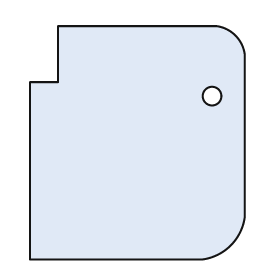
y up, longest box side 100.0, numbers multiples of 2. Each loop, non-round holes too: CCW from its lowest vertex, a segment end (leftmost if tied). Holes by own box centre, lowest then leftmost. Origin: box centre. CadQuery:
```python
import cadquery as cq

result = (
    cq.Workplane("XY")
    .moveTo(-46.0, -50.0)
    .lineTo(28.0, -50.0)
    .threePointArc((40.0, -44.0), (46.0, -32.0))
    .lineTo(46.0, 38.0)
    .threePointArc((42.0, 46.0), (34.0, 50.0))
    .lineTo(-34.0, 50.0)
    .lineTo(-34.0, 26.0)
    .lineTo(-46.0, 26.0)
    .close()
    .moveTo(32.0, 20.0)
    .circle(4.0)
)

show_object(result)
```